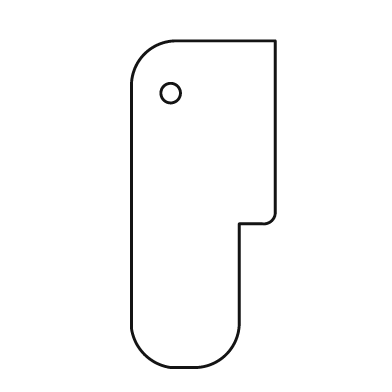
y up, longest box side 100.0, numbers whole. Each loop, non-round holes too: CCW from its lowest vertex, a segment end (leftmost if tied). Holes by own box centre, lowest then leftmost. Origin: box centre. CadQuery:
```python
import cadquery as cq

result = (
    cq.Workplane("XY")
    .moveTo(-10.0, -50.0)
    .lineTo(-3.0, -50.0)
    .threePointArc((7.0, -46.0), (11.0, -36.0))
    .lineTo(11.0, -6.0)
    .lineTo(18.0, -6.0)
    .threePointArc((21.0, -5.0), (22.0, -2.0))
    .lineTo(22.0, 50.0)
    .lineTo(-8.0, 50.0)
    .threePointArc((-18.0, 46.0), (-22.0, 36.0))
    .lineTo(-22.0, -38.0)
    .threePointArc((-18.0, -46.0), (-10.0, -50.0))
    .close()
    .moveTo(-10.0, 34.0)
    .circle(3.0)
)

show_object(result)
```